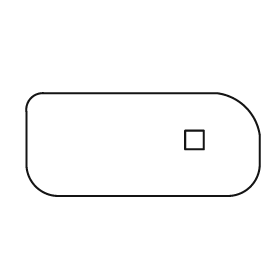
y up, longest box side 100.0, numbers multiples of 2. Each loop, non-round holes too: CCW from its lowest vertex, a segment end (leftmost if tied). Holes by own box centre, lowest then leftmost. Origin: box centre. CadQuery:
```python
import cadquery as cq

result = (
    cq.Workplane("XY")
    .moveTo(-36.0, -22.0)
    .lineTo(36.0, -22.0)
    .threePointArc((46.0, -18.0), (50.0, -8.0))
    .lineTo(50.0, 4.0)
    .threePointArc((44.0, 16.0), (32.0, 22.0))
    .lineTo(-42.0, 22.0)
    .threePointArc((-48.0, 20.0), (-50.0, 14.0))
    .lineTo(-50.0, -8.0)
    .threePointArc((-46.0, -18.0), (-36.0, -22.0))
    .close()
    .moveTo(18.0, -2.0)
    .lineTo(26.0, -2.0)
    .lineTo(26.0, 6.0)
    .lineTo(18.0, 6.0)
    .close()
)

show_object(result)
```